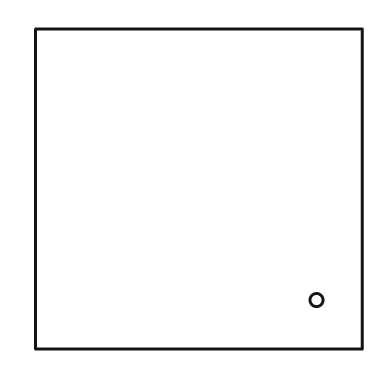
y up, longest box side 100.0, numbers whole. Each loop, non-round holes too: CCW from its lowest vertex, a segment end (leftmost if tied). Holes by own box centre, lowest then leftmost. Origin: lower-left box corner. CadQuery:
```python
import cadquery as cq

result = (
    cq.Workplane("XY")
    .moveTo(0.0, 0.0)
    .lineTo(100.0, 0.0)
    .lineTo(100.0, 98.0)
    .lineTo(0.0, 98.0)
    .close()
    .moveTo(86.0, 15.0)
    .circle(2.0)
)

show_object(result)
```